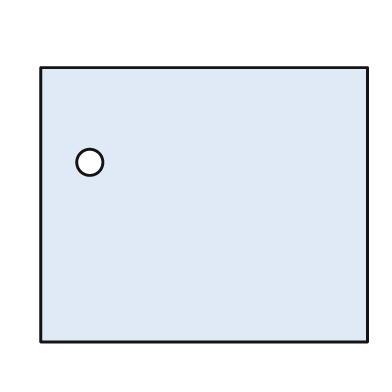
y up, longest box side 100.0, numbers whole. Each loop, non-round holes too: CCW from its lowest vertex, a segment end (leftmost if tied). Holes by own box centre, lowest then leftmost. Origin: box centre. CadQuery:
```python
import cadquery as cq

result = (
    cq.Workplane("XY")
    .moveTo(-50.0, -42.0)
    .lineTo(50.0, -42.0)
    .lineTo(50.0, 42.0)
    .lineTo(-50.0, 42.0)
    .close()
    .moveTo(-35.0, 13.0)
    .circle(4.0)
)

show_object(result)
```